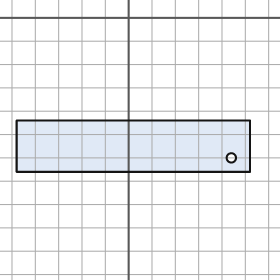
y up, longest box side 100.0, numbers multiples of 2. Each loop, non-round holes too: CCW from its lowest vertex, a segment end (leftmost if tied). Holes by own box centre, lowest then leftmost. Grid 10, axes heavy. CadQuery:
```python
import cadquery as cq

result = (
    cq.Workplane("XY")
    .moveTo(-48.0, -66.0)
    .lineTo(52.0, -66.0)
    .lineTo(52.0, -44.0)
    .lineTo(-48.0, -44.0)
    .close()
    .moveTo(44.0, -60.0)
    .circle(2.0)
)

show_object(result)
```